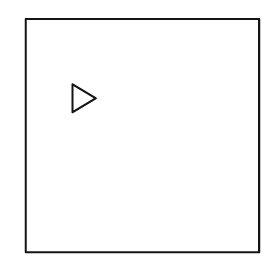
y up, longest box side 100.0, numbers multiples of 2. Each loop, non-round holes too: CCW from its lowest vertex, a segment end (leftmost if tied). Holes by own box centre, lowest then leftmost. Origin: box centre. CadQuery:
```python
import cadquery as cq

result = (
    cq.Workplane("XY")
    .moveTo(-50.0, -50.0)
    .lineTo(50.0, -50.0)
    .lineTo(50.0, 50.0)
    .lineTo(-50.0, 50.0)
    .close()
    .moveTo(-30.0, 10.0)
    .lineTo(-20.0, 16.0)
    .lineTo(-30.0, 22.0)
    .close()
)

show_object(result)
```